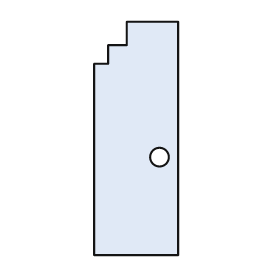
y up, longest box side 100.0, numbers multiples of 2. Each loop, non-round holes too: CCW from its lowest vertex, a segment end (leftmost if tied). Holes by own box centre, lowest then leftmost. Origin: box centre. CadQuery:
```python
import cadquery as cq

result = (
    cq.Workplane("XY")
    .moveTo(-18.0, -50.0)
    .lineTo(18.0, -50.0)
    .lineTo(18.0, 50.0)
    .lineTo(-4.0, 50.0)
    .lineTo(-4.0, 40.0)
    .lineTo(-12.0, 40.0)
    .lineTo(-12.0, 32.0)
    .lineTo(-18.0, 32.0)
    .close()
    .moveTo(10.0, -8.0)
    .circle(4.0)
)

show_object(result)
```